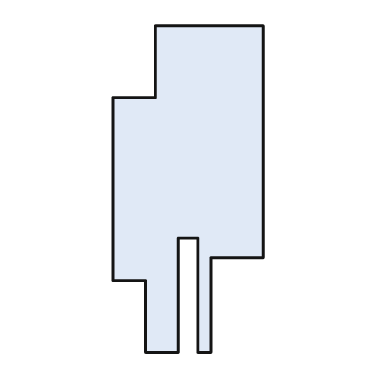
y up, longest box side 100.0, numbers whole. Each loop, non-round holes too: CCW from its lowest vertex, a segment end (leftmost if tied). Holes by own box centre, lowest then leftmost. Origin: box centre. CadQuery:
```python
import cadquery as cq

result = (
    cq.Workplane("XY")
    .moveTo(-13.0, -50.0)
    .lineTo(-3.0, -50.0)
    .lineTo(-3.0, -15.0)
    .lineTo(3.0, -15.0)
    .lineTo(3.0, -50.0)
    .lineTo(7.0, -50.0)
    .lineTo(7.0, -21.0)
    .lineTo(23.0, -21.0)
    .lineTo(23.0, 50.0)
    .lineTo(-10.0, 50.0)
    .lineTo(-10.0, 28.0)
    .lineTo(-23.0, 28.0)
    .lineTo(-23.0, -28.0)
    .lineTo(-13.0, -28.0)
    .close()
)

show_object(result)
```